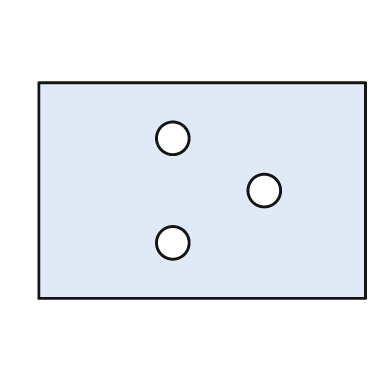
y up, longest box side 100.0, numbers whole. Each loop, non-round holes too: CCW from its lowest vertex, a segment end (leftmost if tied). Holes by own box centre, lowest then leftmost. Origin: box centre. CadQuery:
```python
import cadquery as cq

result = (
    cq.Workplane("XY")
    .moveTo(-50.0, -33.0)
    .lineTo(50.0, -33.0)
    .lineTo(50.0, 33.0)
    .lineTo(-50.0, 33.0)
    .close()
    .moveTo(-9.0, -16.0)
    .circle(5.0)
    .moveTo(19.0, 0.0)
    .circle(5.0)
    .moveTo(-9.0, 16.0)
    .circle(5.0)
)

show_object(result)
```